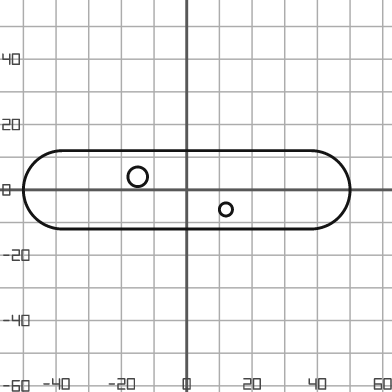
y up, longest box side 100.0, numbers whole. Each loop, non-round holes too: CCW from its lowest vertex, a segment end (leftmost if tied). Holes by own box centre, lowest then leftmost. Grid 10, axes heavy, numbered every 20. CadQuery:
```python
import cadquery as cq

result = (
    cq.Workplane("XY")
    .moveTo(-38.0, -12.0)
    .lineTo(38.0, -12.0)
    .threePointArc((50.0, 0.0), (38.0, 12.0))
    .lineTo(-38.0, 12.0)
    .threePointArc((-50.0, 0.0), (-38.0, -12.0))
    .close()
    .moveTo(12.0, -6.0)
    .circle(2.0)
    .moveTo(-15.0, 4.0)
    .circle(3.0)
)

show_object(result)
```